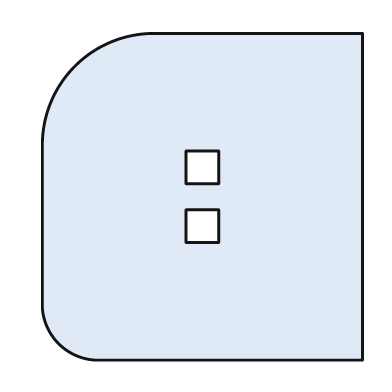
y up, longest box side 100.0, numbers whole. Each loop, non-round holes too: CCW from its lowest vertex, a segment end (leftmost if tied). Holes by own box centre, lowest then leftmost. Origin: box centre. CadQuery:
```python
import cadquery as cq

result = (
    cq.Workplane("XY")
    .moveTo(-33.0, -50.0)
    .lineTo(49.0, -50.0)
    .lineTo(49.0, 50.0)
    .lineTo(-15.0, 50.0)
    .threePointArc((-39.0, 40.0), (-49.0, 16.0))
    .lineTo(-49.0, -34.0)
    .threePointArc((-44.0, -45.0), (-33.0, -50.0))
    .close()
    .moveTo(-5.0, -14.0)
    .lineTo(5.0, -14.0)
    .lineTo(5.0, -4.0)
    .lineTo(-5.0, -4.0)
    .close()
    .moveTo(-5.0, 4.0)
    .lineTo(5.0, 4.0)
    .lineTo(5.0, 14.0)
    .lineTo(-5.0, 14.0)
    .close()
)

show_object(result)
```